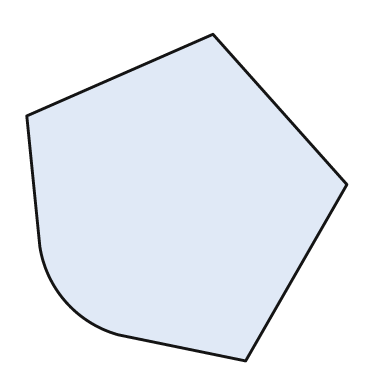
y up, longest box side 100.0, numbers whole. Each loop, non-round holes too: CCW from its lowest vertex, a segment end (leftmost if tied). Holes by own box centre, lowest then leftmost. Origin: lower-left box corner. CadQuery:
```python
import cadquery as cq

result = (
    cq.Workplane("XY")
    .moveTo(67.0, 0.0)
    .lineTo(98.0, 54.0)
    .lineTo(57.0, 100.0)
    .lineTo(0.0, 75.0)
    .lineTo(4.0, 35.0)
    .threePointArc((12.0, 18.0), (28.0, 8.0))
    .close()
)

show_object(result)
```